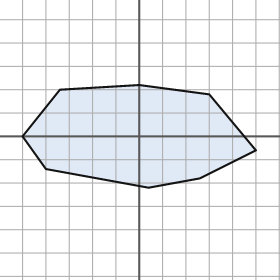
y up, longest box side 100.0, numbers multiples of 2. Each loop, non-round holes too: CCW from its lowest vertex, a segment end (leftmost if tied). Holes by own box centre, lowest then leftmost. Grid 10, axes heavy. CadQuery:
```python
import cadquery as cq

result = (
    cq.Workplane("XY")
    .moveTo(4.0, -22.0)
    .lineTo(26.0, -18.0)
    .lineTo(50.0, -6.0)
    .lineTo(30.0, 18.0)
    .lineTo(0.0, 22.0)
    .lineTo(-34.0, 20.0)
    .lineTo(-50.0, 0.0)
    .lineTo(-40.0, -14.0)
    .close()
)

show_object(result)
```